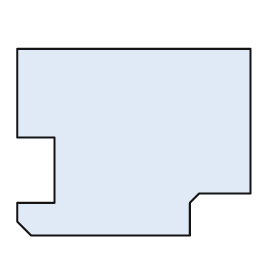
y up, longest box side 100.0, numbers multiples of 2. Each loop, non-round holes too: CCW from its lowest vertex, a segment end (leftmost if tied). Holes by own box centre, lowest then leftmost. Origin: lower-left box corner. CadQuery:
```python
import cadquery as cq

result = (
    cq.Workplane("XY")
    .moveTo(6.0, 0.0)
    .lineTo(74.0, 0.0)
    .lineTo(74.0, 14.0)
    .lineTo(78.0, 18.0)
    .lineTo(100.0, 18.0)
    .lineTo(100.0, 80.0)
    .lineTo(0.0, 80.0)
    .lineTo(0.0, 42.0)
    .lineTo(16.0, 42.0)
    .lineTo(16.0, 14.0)
    .lineTo(0.0, 14.0)
    .lineTo(0.0, 6.0)
    .close()
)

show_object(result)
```